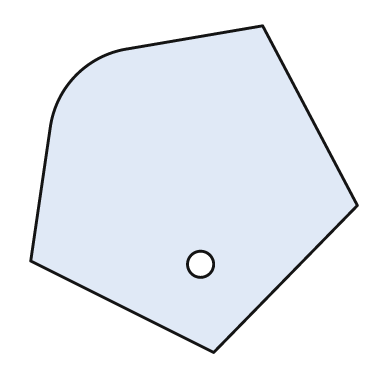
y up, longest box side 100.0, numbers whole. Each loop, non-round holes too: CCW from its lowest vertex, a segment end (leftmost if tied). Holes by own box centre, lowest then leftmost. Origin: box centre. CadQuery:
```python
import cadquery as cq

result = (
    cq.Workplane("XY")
    .moveTo(6.0, -50.0)
    .lineTo(50.0, -5.0)
    .lineTo(21.0, 50.0)
    .lineTo(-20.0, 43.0)
    .threePointArc((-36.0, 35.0), (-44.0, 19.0))
    .lineTo(-50.0, -22.0)
    .close()
    .moveTo(2.0, -23.0)
    .circle(4.0)
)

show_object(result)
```